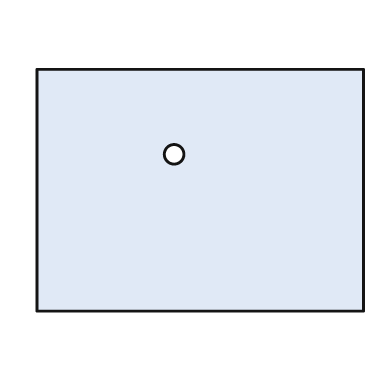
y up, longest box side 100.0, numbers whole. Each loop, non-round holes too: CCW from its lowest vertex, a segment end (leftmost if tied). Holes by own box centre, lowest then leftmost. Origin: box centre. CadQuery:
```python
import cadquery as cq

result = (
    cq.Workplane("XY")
    .moveTo(-50.0, -37.0)
    .lineTo(50.0, -37.0)
    .lineTo(50.0, 37.0)
    .lineTo(-50.0, 37.0)
    .close()
    .moveTo(-8.0, 11.0)
    .circle(3.0)
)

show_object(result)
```